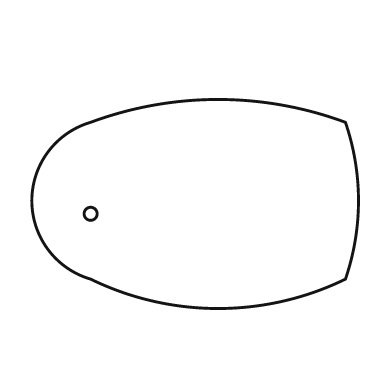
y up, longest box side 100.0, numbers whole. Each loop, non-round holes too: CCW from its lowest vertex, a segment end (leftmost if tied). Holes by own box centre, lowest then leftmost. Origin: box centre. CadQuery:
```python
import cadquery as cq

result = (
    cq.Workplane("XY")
    .moveTo(-32.0, -23.0)
    .threePointArc((7.0, -32.0), (46.0, -23.0))
    .threePointArc((50.0, 1.0), (46.0, 25.0))
    .threePointArc((7.0, 32.0), (-32.0, 25.0))
    .threePointArc((-50.0, 1.0), (-32.0, -23.0))
    .close()
    .moveTo(-32.0, -3.0)
    .circle(2.0)
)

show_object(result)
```